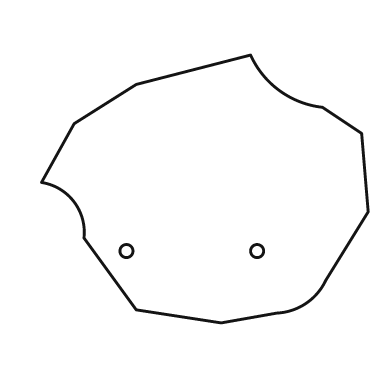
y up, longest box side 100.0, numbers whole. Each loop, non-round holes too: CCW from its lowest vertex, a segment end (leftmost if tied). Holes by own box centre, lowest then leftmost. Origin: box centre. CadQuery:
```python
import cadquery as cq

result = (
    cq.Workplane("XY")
    .moveTo(5.0, -41.0)
    .lineTo(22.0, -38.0)
    .threePointArc((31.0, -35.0), (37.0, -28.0))
    .lineTo(50.0, -7.0)
    .lineTo(48.0, 17.0)
    .lineTo(36.0, 25.0)
    .threePointArc((23.0, 30.0), (14.0, 41.0))
    .lineTo(-21.0, 32.0)
    .lineTo(-40.0, 20.0)
    .lineTo(-50.0, 2.0)
    .threePointArc((-40.0, -4.0), (-37.0, -15.0))
    .lineTo(-21.0, -37.0)
    .close()
    .moveTo(-24.0, -19.0)
    .circle(2.0)
    .moveTo(16.0, -19.0)
    .circle(2.0)
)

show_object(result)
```